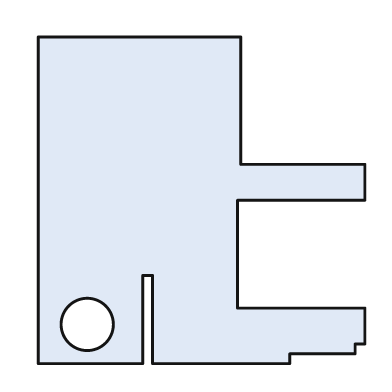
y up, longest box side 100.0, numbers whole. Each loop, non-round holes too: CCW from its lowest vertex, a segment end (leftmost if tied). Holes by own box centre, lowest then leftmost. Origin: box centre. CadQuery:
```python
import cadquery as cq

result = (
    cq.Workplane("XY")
    .moveTo(-50.0, -50.0)
    .lineTo(-18.0, -50.0)
    .lineTo(-18.0, -23.0)
    .lineTo(-15.0, -23.0)
    .lineTo(-15.0, -50.0)
    .lineTo(27.0, -50.0)
    .lineTo(27.0, -47.0)
    .lineTo(47.0, -47.0)
    .lineTo(47.0, -44.0)
    .lineTo(50.0, -44.0)
    .lineTo(50.0, -33.0)
    .lineTo(11.0, -33.0)
    .lineTo(11.0, 0.0)
    .lineTo(50.0, 0.0)
    .lineTo(50.0, 11.0)
    .lineTo(12.0, 11.0)
    .lineTo(12.0, 50.0)
    .lineTo(-50.0, 50.0)
    .close()
    .moveTo(-35.0, -38.0)
    .circle(8.0)
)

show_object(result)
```